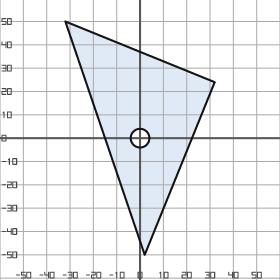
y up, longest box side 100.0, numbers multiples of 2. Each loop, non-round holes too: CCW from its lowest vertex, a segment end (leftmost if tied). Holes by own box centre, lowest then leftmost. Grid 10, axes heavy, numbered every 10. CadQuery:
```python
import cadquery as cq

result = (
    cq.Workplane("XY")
    .moveTo(2.0, -50.0)
    .lineTo(32.0, 24.0)
    .lineTo(-32.0, 50.0)
    .close()
    .moveTo(0.0, 0.0)
    .circle(4.0)
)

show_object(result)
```